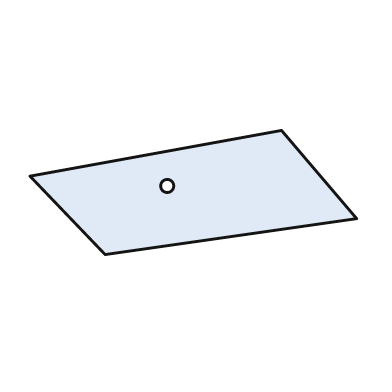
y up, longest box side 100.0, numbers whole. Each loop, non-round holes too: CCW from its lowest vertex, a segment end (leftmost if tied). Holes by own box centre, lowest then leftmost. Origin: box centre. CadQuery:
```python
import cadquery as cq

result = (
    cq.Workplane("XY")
    .moveTo(-27.0, -19.0)
    .lineTo(50.0, -8.0)
    .lineTo(27.0, 19.0)
    .lineTo(-50.0, 5.0)
    .close()
    .moveTo(-8.0, 2.0)
    .circle(2.0)
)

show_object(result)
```